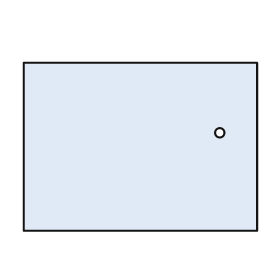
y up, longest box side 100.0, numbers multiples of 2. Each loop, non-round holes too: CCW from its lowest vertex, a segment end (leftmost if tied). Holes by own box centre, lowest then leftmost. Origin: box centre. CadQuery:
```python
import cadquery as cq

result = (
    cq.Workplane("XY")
    .moveTo(-50.0, -36.0)
    .lineTo(50.0, -36.0)
    .lineTo(50.0, 36.0)
    .lineTo(-50.0, 36.0)
    .close()
    .moveTo(34.0, 6.0)
    .circle(2.0)
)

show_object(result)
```